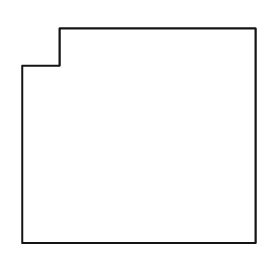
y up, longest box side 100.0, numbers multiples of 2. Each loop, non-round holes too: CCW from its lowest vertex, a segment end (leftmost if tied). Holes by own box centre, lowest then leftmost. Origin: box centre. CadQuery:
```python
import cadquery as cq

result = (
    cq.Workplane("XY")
    .moveTo(-50.0, -46.0)
    .lineTo(50.0, -46.0)
    .lineTo(50.0, 46.0)
    .lineTo(-34.0, 46.0)
    .lineTo(-34.0, 30.0)
    .lineTo(-50.0, 30.0)
    .close()
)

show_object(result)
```